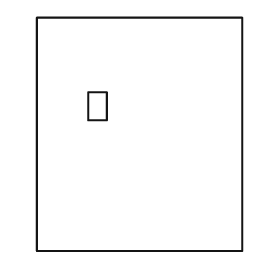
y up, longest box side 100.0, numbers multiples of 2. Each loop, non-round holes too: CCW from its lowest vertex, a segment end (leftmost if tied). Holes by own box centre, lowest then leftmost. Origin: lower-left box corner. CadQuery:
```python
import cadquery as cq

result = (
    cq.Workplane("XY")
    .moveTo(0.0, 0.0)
    .lineTo(88.0, 0.0)
    .lineTo(88.0, 100.0)
    .lineTo(0.0, 100.0)
    .close()
    .moveTo(22.0, 56.0)
    .lineTo(30.0, 56.0)
    .lineTo(30.0, 68.0)
    .lineTo(22.0, 68.0)
    .close()
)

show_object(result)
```